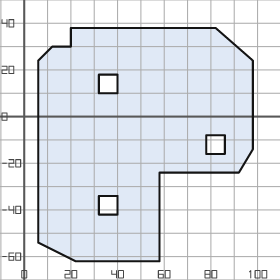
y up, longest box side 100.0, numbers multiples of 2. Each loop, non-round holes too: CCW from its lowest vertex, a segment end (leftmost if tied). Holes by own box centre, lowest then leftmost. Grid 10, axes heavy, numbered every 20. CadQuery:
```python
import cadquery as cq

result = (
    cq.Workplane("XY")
    .moveTo(22.0, -62.0)
    .lineTo(58.0, -62.0)
    .lineTo(58.0, -24.0)
    .lineTo(92.0, -24.0)
    .lineTo(98.0, -14.0)
    .lineTo(98.0, 24.0)
    .lineTo(82.0, 38.0)
    .lineTo(20.0, 38.0)
    .lineTo(20.0, 30.0)
    .lineTo(12.0, 30.0)
    .lineTo(6.0, 24.0)
    .lineTo(6.0, -54.0)
    .close()
    .moveTo(32.0, -42.0)
    .lineTo(40.0, -42.0)
    .lineTo(40.0, -34.0)
    .lineTo(32.0, -34.0)
    .close()
    .moveTo(78.0, -16.0)
    .lineTo(86.0, -16.0)
    .lineTo(86.0, -8.0)
    .lineTo(78.0, -8.0)
    .close()
    .moveTo(32.0, 10.0)
    .lineTo(40.0, 10.0)
    .lineTo(40.0, 18.0)
    .lineTo(32.0, 18.0)
    .close()
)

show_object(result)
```